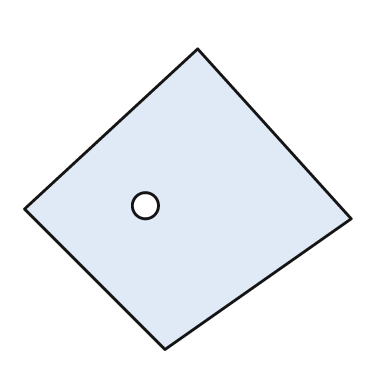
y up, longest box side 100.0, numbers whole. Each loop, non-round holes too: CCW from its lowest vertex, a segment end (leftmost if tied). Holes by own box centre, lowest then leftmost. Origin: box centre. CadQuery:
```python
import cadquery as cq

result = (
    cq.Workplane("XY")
    .moveTo(-7.0, -46.0)
    .lineTo(50.0, -6.0)
    .lineTo(3.0, 46.0)
    .lineTo(-50.0, -3.0)
    .close()
    .moveTo(-13.0, -2.0)
    .circle(4.0)
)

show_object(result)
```